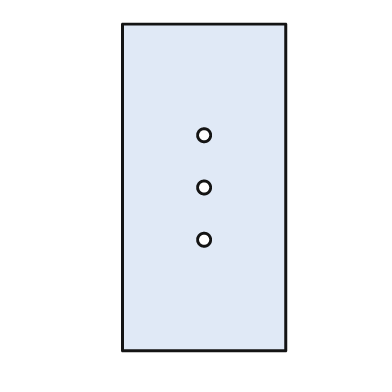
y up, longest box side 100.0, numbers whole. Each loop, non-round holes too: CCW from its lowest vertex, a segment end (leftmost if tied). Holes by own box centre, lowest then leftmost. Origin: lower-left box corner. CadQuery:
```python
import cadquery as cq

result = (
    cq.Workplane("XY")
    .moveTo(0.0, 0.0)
    .lineTo(50.0, 0.0)
    .lineTo(50.0, 100.0)
    .lineTo(0.0, 100.0)
    .close()
    .moveTo(25.0, 34.0)
    .circle(2.0)
    .moveTo(25.0, 50.0)
    .circle(2.0)
    .moveTo(25.0, 66.0)
    .circle(2.0)
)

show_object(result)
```